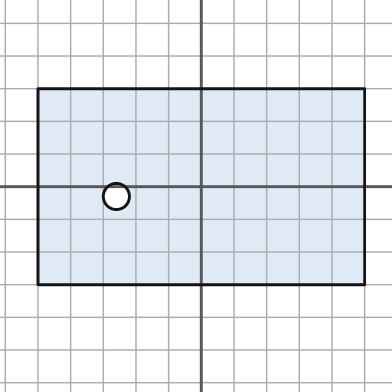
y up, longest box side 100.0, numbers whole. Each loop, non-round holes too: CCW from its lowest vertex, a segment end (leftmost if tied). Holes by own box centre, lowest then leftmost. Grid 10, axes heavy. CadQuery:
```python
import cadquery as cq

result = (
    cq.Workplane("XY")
    .moveTo(-50.0, -30.0)
    .lineTo(50.0, -30.0)
    .lineTo(50.0, 30.0)
    .lineTo(-50.0, 30.0)
    .close()
    .moveTo(-26.0, -3.0)
    .circle(4.0)
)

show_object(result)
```